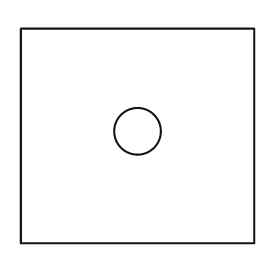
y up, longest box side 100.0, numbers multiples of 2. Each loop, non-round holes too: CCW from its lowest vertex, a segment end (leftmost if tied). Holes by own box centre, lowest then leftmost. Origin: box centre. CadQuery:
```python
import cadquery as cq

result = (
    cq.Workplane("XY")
    .moveTo(-50.0, -46.0)
    .lineTo(50.0, -46.0)
    .lineTo(50.0, 46.0)
    .lineTo(-50.0, 46.0)
    .close()
    .moveTo(0.0, 2.0)
    .circle(10.0)
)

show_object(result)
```